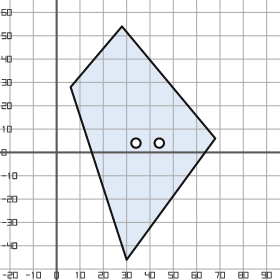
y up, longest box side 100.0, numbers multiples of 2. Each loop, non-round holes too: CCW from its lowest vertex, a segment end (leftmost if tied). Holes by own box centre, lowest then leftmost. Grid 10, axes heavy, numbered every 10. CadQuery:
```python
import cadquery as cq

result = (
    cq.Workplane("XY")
    .moveTo(30.0, -46.0)
    .lineTo(68.0, 6.0)
    .lineTo(28.0, 54.0)
    .lineTo(6.0, 28.0)
    .close()
    .moveTo(34.0, 4.0)
    .circle(2.0)
    .moveTo(44.0, 4.0)
    .circle(2.0)
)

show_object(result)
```